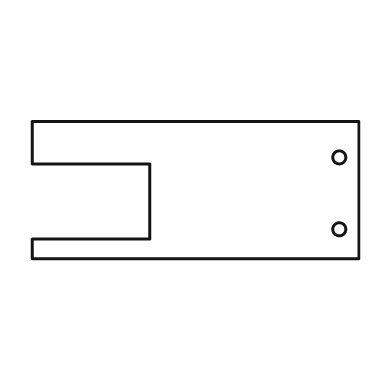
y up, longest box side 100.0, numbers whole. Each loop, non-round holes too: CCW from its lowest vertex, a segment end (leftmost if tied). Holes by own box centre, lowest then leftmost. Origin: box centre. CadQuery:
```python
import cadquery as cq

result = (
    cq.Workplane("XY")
    .moveTo(-50.0, -21.0)
    .lineTo(50.0, -21.0)
    .lineTo(50.0, 21.0)
    .lineTo(-50.0, 21.0)
    .lineTo(-50.0, 8.0)
    .lineTo(-14.0, 8.0)
    .lineTo(-14.0, -15.0)
    .lineTo(-50.0, -15.0)
    .close()
    .moveTo(44.0, -12.0)
    .circle(2.0)
    .moveTo(44.0, 10.0)
    .circle(2.0)
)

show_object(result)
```